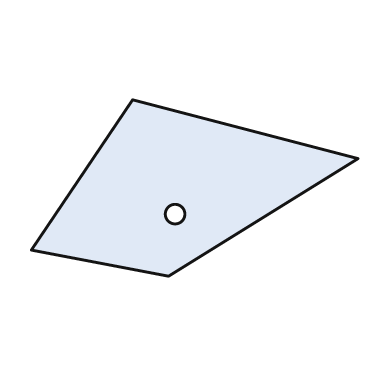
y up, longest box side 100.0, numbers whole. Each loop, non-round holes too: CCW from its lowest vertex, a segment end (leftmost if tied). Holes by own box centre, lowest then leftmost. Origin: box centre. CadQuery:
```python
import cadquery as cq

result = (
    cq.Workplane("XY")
    .moveTo(-8.0, -27.0)
    .lineTo(50.0, 9.0)
    .lineTo(-19.0, 27.0)
    .lineTo(-50.0, -19.0)
    .close()
    .moveTo(-6.0, -8.0)
    .circle(3.0)
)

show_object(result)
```